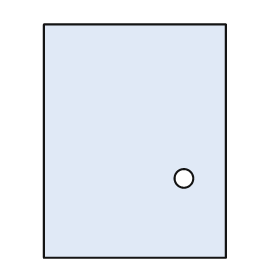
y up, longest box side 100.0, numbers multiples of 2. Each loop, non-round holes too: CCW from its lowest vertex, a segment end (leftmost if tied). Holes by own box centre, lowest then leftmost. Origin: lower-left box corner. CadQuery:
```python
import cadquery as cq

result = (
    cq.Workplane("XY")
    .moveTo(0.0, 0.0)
    .lineTo(78.0, 0.0)
    .lineTo(78.0, 100.0)
    .lineTo(0.0, 100.0)
    .close()
    .moveTo(60.0, 34.0)
    .circle(4.0)
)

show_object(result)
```